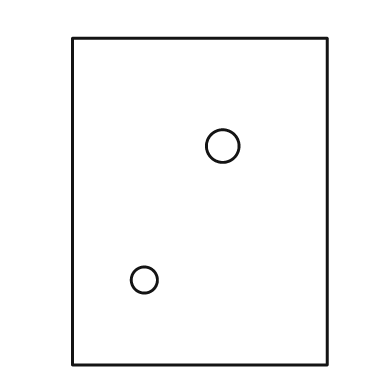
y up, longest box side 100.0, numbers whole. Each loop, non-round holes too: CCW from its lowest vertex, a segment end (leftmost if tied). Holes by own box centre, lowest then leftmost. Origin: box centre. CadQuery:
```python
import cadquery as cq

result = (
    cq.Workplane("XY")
    .moveTo(-39.0, -50.0)
    .lineTo(39.0, -50.0)
    .lineTo(39.0, 50.0)
    .lineTo(-39.0, 50.0)
    .close()
    .moveTo(-17.0, -24.0)
    .circle(4.0)
    .moveTo(7.0, 17.0)
    .circle(5.0)
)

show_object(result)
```